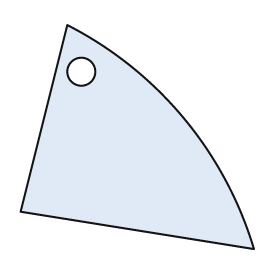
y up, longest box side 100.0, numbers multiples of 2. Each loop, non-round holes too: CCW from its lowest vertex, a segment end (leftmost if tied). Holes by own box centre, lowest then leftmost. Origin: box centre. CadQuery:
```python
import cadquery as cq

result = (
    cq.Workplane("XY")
    .moveTo(50.0, -48.0)
    .threePointArc((20.0, 8.0), (-30.0, 48.0))
    .lineTo(-50.0, -32.0)
    .close()
    .moveTo(-24.0, 28.0)
    .circle(6.0)
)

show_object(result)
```